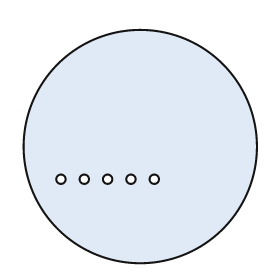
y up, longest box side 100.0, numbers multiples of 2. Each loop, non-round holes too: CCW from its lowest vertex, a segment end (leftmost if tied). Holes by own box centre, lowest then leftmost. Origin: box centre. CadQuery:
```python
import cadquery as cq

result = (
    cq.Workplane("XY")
    .moveTo(0.0, 0.0)
    .circle(50.0)
    .moveTo(-34.0, -14.0)
    .circle(2.0)
    .moveTo(-24.0, -14.0)
    .circle(2.0)
    .moveTo(-14.0, -14.0)
    .circle(2.0)
    .moveTo(-4.0, -14.0)
    .circle(2.0)
    .moveTo(6.0, -14.0)
    .circle(2.0)
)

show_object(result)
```